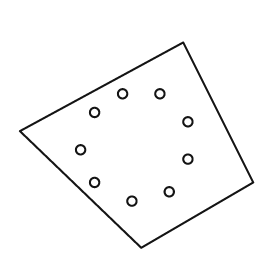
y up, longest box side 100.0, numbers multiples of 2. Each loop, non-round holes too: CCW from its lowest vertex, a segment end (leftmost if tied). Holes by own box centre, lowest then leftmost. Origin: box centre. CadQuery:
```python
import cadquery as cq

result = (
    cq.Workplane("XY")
    .moveTo(2.0, -44.0)
    .lineTo(50.0, -16.0)
    .lineTo(20.0, 44.0)
    .lineTo(-50.0, 6.0)
    .close()
    .moveTo(-2.0, -24.0)
    .circle(2.0)
    .moveTo(14.0, -20.0)
    .circle(2.0)
    .moveTo(-18.0, -16.0)
    .circle(2.0)
    .moveTo(22.0, -6.0)
    .circle(2.0)
    .moveTo(-24.0, -2.0)
    .circle(2.0)
    .moveTo(22.0, 10.0)
    .circle(2.0)
    .moveTo(-18.0, 14.0)
    .circle(2.0)
    .moveTo(-6.0, 22.0)
    .circle(2.0)
    .moveTo(10.0, 22.0)
    .circle(2.0)
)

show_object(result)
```